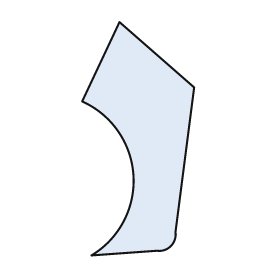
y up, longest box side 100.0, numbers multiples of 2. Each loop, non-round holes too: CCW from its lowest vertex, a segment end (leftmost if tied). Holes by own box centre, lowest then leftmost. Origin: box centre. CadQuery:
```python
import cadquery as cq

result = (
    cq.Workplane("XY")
    .moveTo(-20.0, -50.0)
    .lineTo(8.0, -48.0)
    .threePointArc((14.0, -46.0), (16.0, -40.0))
    .lineTo(24.0, 22.0)
    .lineTo(-8.0, 50.0)
    .lineTo(-24.0, 16.0)
    .threePointArc((-2.0, -16.0), (-20.0, -50.0))
    .close()
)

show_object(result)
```